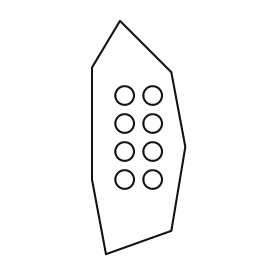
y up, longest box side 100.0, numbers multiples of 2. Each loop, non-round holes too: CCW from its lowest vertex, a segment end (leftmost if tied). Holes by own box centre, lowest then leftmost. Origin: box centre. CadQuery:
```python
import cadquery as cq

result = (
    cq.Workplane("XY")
    .moveTo(-14.0, -50.0)
    .lineTo(14.0, -40.0)
    .lineTo(20.0, -4.0)
    .lineTo(14.0, 28.0)
    .lineTo(-8.0, 50.0)
    .lineTo(-20.0, 30.0)
    .lineTo(-20.0, -18.0)
    .close()
    .moveTo(-6.0, -18.0)
    .circle(4.0)
    .moveTo(6.0, -18.0)
    .circle(4.0)
    .moveTo(-6.0, -6.0)
    .circle(4.0)
    .moveTo(6.0, -6.0)
    .circle(4.0)
    .moveTo(-6.0, 6.0)
    .circle(4.0)
    .moveTo(6.0, 6.0)
    .circle(4.0)
    .moveTo(-6.0, 18.0)
    .circle(4.0)
    .moveTo(6.0, 18.0)
    .circle(4.0)
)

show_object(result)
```